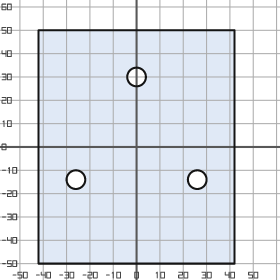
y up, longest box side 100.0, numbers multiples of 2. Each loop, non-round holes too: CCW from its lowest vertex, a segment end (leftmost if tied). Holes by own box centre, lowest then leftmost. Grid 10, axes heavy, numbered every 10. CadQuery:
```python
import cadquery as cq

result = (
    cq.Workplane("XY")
    .moveTo(-42.0, -50.0)
    .lineTo(42.0, -50.0)
    .lineTo(42.0, 50.0)
    .lineTo(-42.0, 50.0)
    .close()
    .moveTo(-26.0, -14.0)
    .circle(4.0)
    .moveTo(26.0, -14.0)
    .circle(4.0)
    .moveTo(0.0, 30.0)
    .circle(4.0)
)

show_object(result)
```